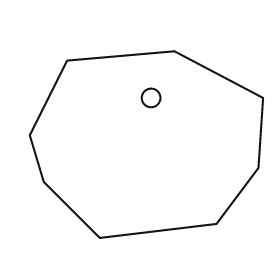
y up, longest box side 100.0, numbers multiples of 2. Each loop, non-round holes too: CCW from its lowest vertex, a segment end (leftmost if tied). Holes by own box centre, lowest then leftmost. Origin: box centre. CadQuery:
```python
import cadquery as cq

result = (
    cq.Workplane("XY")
    .moveTo(-20.0, -40.0)
    .lineTo(30.0, -34.0)
    .lineTo(48.0, -10.0)
    .lineTo(50.0, 20.0)
    .lineTo(12.0, 40.0)
    .lineTo(-34.0, 36.0)
    .lineTo(-50.0, 4.0)
    .lineTo(-44.0, -16.0)
    .close()
    .moveTo(2.0, 20.0)
    .circle(4.0)
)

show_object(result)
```